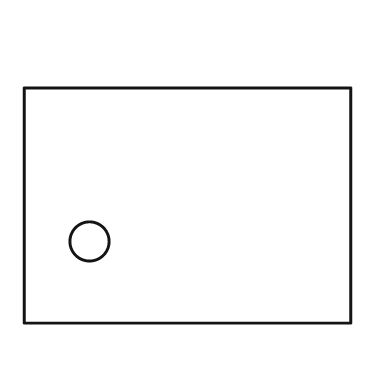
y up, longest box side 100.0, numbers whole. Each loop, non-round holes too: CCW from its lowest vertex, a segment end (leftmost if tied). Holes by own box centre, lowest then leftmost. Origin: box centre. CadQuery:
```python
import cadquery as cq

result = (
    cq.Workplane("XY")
    .moveTo(-50.0, -36.0)
    .lineTo(50.0, -36.0)
    .lineTo(50.0, 36.0)
    .lineTo(-50.0, 36.0)
    .close()
    .moveTo(-30.0, -11.0)
    .circle(6.0)
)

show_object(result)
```